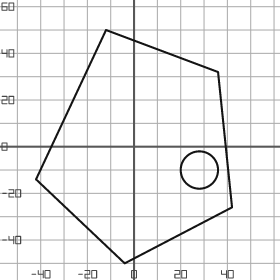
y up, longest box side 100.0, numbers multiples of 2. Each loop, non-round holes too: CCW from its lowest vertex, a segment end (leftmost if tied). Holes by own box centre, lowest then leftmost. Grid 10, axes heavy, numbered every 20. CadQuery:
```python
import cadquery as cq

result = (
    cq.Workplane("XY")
    .moveTo(-4.0, -50.0)
    .lineTo(42.0, -26.0)
    .lineTo(36.0, 32.0)
    .lineTo(-12.0, 50.0)
    .lineTo(-42.0, -14.0)
    .close()
    .moveTo(28.0, -10.0)
    .circle(8.0)
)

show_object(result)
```